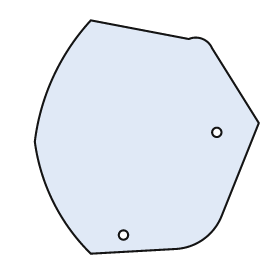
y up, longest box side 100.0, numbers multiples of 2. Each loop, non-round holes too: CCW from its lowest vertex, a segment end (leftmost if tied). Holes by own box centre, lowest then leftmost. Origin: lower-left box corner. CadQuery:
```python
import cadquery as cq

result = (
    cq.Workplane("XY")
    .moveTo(24.0, 0.0)
    .lineTo(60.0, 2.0)
    .threePointArc((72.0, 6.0), (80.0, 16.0))
    .lineTo(96.0, 56.0)
    .lineTo(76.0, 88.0)
    .threePointArc((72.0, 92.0), (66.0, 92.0))
    .lineTo(24.0, 100.0)
    .threePointArc((8.0, 76.0), (0.0, 48.0))
    .threePointArc((8.0, 22.0), (24.0, 0.0))
    .close()
    .moveTo(38.0, 8.0)
    .circle(2.0)
    .moveTo(78.0, 52.0)
    .circle(2.0)
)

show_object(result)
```